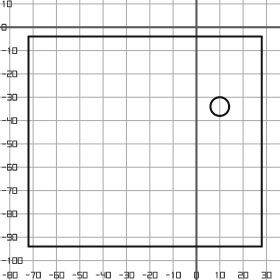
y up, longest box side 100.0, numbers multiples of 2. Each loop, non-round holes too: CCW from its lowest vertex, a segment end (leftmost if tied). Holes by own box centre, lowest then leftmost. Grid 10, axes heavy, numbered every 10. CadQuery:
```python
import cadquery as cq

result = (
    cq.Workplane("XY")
    .moveTo(-72.0, -94.0)
    .lineTo(28.0, -94.0)
    .lineTo(28.0, -4.0)
    .lineTo(-72.0, -4.0)
    .close()
    .moveTo(10.0, -34.0)
    .circle(4.0)
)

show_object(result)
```